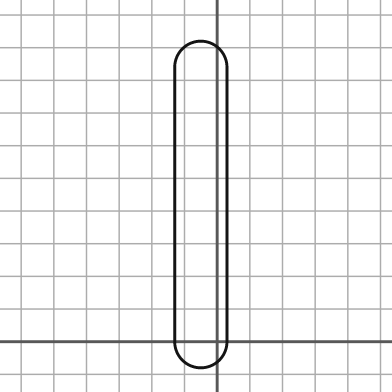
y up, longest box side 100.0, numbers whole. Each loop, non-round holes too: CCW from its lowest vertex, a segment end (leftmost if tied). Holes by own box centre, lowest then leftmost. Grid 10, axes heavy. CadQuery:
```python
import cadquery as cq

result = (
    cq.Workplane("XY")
    .moveTo(-13.0, 0.0)
    .threePointArc((-5.0, -8.0), (3.0, 0.0))
    .lineTo(3.0, 84.0)
    .threePointArc((-5.0, 92.0), (-13.0, 84.0))
    .close()
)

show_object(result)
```